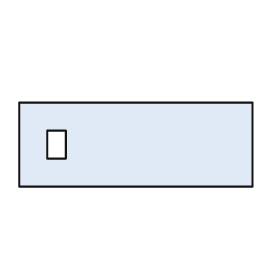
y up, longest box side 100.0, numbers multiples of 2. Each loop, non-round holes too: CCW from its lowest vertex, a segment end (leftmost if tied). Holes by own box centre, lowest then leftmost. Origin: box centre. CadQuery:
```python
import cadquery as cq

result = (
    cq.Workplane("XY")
    .moveTo(-50.0, -18.0)
    .lineTo(50.0, -18.0)
    .lineTo(50.0, 18.0)
    .lineTo(-50.0, 18.0)
    .close()
    .moveTo(-38.0, -6.0)
    .lineTo(-30.0, -6.0)
    .lineTo(-30.0, 6.0)
    .lineTo(-38.0, 6.0)
    .close()
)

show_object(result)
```